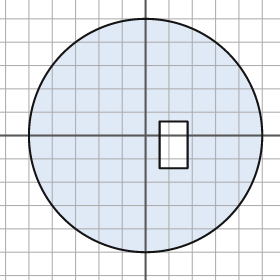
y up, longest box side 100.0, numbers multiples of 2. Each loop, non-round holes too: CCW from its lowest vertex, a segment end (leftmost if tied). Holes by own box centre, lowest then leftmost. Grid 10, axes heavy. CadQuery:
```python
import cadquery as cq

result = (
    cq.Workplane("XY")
    .moveTo(0.0, 0.0)
    .circle(50.0)
    .moveTo(6.0, -14.0)
    .lineTo(18.0, -14.0)
    .lineTo(18.0, 6.0)
    .lineTo(6.0, 6.0)
    .close()
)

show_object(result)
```